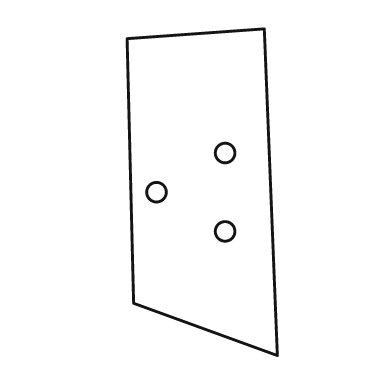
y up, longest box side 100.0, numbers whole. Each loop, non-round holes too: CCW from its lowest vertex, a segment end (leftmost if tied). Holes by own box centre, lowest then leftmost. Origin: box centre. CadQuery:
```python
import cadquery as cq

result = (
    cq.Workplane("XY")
    .moveTo(23.0, -50.0)
    .lineTo(19.0, 50.0)
    .lineTo(-23.0, 47.0)
    .lineTo(-21.0, -34.0)
    .close()
    .moveTo(7.0, -12.0)
    .circle(3.0)
    .moveTo(-14.0, 0.0)
    .circle(3.0)
    .moveTo(7.0, 12.0)
    .circle(3.0)
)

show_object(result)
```